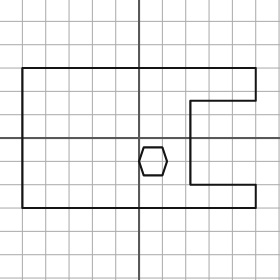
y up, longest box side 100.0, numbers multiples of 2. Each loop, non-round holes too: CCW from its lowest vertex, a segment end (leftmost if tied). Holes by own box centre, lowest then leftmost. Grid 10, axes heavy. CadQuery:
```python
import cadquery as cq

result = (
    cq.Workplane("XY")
    .moveTo(-50.0, -30.0)
    .lineTo(50.0, -30.0)
    .lineTo(50.0, -20.0)
    .lineTo(22.0, -20.0)
    .lineTo(22.0, 16.0)
    .lineTo(50.0, 16.0)
    .lineTo(50.0, 30.0)
    .lineTo(-50.0, 30.0)
    .close()
    .moveTo(2.0, -16.0)
    .lineTo(10.0, -16.0)
    .lineTo(12.0, -10.0)
    .lineTo(10.0, -4.0)
    .lineTo(2.0, -4.0)
    .lineTo(0.0, -10.0)
    .close()
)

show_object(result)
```